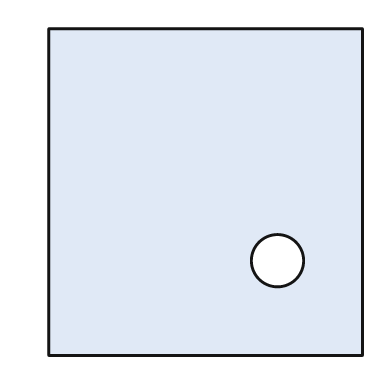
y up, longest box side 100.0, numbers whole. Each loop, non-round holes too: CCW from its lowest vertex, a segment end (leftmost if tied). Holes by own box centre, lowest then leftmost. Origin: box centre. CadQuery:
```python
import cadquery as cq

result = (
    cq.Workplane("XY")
    .moveTo(-48.0, -50.0)
    .lineTo(48.0, -50.0)
    .lineTo(48.0, 50.0)
    .lineTo(-48.0, 50.0)
    .close()
    .moveTo(22.0, -21.0)
    .circle(8.0)
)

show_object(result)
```